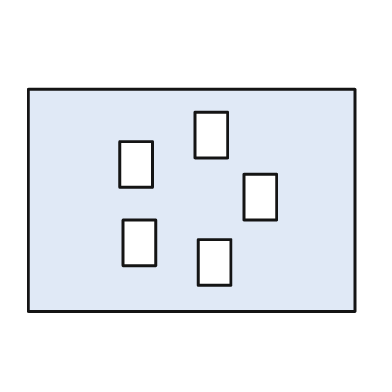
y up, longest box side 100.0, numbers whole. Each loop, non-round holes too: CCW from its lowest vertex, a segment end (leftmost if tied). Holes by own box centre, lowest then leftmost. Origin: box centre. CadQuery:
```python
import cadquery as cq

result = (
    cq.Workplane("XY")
    .moveTo(-50.0, -34.0)
    .lineTo(50.0, -34.0)
    .lineTo(50.0, 34.0)
    .lineTo(-50.0, 34.0)
    .close()
    .moveTo(2.0, -26.0)
    .lineTo(12.0, -26.0)
    .lineTo(12.0, -12.0)
    .lineTo(2.0, -12.0)
    .close()
    .moveTo(-21.0, -20.0)
    .lineTo(-11.0, -20.0)
    .lineTo(-11.0, -6.0)
    .lineTo(-21.0, -6.0)
    .close()
    .moveTo(16.0, -6.0)
    .lineTo(26.0, -6.0)
    .lineTo(26.0, 8.0)
    .lineTo(16.0, 8.0)
    .close()
    .moveTo(-22.0, 4.0)
    .lineTo(-12.0, 4.0)
    .lineTo(-12.0, 18.0)
    .lineTo(-22.0, 18.0)
    .close()
    .moveTo(1.0, 13.0)
    .lineTo(11.0, 13.0)
    .lineTo(11.0, 27.0)
    .lineTo(1.0, 27.0)
    .close()
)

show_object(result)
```